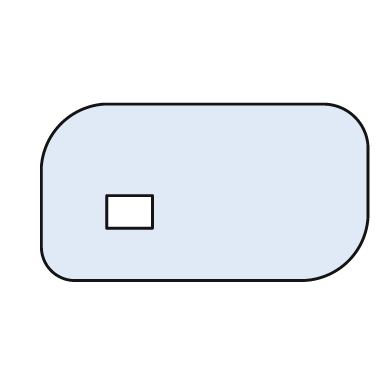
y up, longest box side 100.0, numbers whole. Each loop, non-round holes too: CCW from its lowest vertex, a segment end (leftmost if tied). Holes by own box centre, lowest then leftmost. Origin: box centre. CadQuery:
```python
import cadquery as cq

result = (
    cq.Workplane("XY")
    .moveTo(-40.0, -27.0)
    .lineTo(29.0, -27.0)
    .threePointArc((44.0, -21.0), (50.0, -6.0))
    .lineTo(50.0, 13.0)
    .threePointArc((46.0, 23.0), (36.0, 27.0))
    .lineTo(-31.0, 27.0)
    .threePointArc((-44.0, 21.0), (-50.0, 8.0))
    .lineTo(-50.0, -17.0)
    .threePointArc((-47.0, -24.0), (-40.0, -27.0))
    .close()
    .moveTo(-30.0, -11.0)
    .lineTo(-16.0, -11.0)
    .lineTo(-16.0, -1.0)
    .lineTo(-30.0, -1.0)
    .close()
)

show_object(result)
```